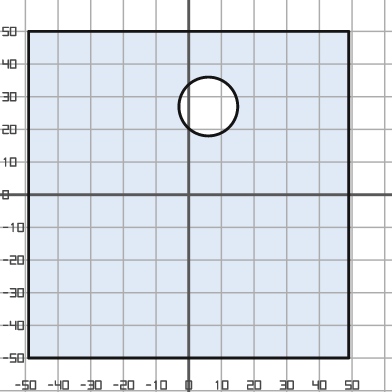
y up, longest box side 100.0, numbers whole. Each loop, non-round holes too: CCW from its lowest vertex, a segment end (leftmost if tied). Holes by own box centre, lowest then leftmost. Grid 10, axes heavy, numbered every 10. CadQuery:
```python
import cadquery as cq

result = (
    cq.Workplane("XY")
    .moveTo(-49.0, -50.0)
    .lineTo(49.0, -50.0)
    .lineTo(49.0, 50.0)
    .lineTo(-49.0, 50.0)
    .close()
    .moveTo(6.0, 27.0)
    .circle(9.0)
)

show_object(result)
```